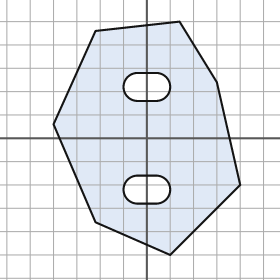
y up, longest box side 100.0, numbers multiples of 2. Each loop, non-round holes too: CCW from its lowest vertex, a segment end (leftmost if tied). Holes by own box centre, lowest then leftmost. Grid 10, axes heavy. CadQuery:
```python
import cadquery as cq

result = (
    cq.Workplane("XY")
    .moveTo(10.0, -50.0)
    .lineTo(40.0, -20.0)
    .lineTo(30.0, 24.0)
    .lineTo(14.0, 50.0)
    .lineTo(-22.0, 46.0)
    .lineTo(-40.0, 6.0)
    .lineTo(-22.0, -36.0)
    .close()
    .moveTo(-4.0, -28.0)
    .lineTo(4.0, -28.0)
    .threePointArc((10.0, -22.0), (4.0, -16.0))
    .lineTo(-4.0, -16.0)
    .threePointArc((-10.0, -22.0), (-4.0, -28.0))
    .close()
    .moveTo(-4.0, 16.0)
    .lineTo(4.0, 16.0)
    .threePointArc((10.0, 22.0), (4.0, 28.0))
    .lineTo(-4.0, 28.0)
    .threePointArc((-10.0, 22.0), (-4.0, 16.0))
    .close()
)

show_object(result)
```